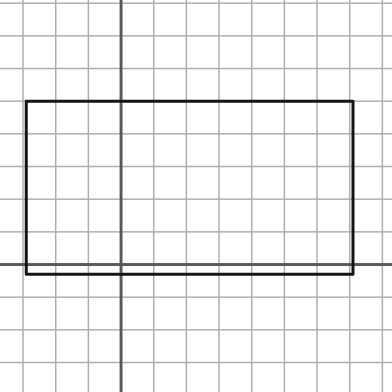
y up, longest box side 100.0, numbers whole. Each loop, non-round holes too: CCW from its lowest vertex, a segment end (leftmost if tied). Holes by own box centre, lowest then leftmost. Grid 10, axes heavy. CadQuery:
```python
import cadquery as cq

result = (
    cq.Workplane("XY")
    .moveTo(-29.0, -3.0)
    .lineTo(71.0, -3.0)
    .lineTo(71.0, 50.0)
    .lineTo(-29.0, 50.0)
    .close()
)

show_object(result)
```